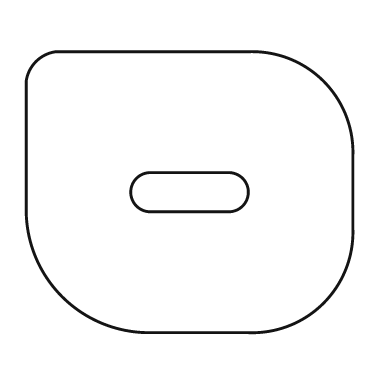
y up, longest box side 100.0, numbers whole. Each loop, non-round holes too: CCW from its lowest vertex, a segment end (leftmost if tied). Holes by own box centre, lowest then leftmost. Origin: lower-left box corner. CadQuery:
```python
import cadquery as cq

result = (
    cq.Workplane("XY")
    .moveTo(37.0, 0.0)
    .lineTo(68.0, 0.0)
    .threePointArc((91.0, 9.0), (100.0, 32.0))
    .lineTo(100.0, 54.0)
    .threePointArc((91.0, 77.0), (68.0, 86.0))
    .lineTo(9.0, 86.0)
    .threePointArc((3.0, 83.0), (0.0, 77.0))
    .lineTo(0.0, 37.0)
    .threePointArc((11.0, 11.0), (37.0, 0.0))
    .close()
    .moveTo(38.0, 37.0)
    .lineTo(62.0, 37.0)
    .threePointArc((68.0, 43.0), (62.0, 49.0))
    .lineTo(38.0, 49.0)
    .threePointArc((32.0, 43.0), (38.0, 37.0))
    .close()
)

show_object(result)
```